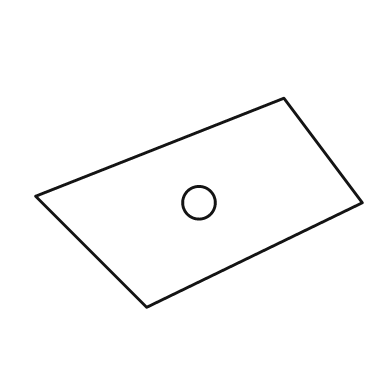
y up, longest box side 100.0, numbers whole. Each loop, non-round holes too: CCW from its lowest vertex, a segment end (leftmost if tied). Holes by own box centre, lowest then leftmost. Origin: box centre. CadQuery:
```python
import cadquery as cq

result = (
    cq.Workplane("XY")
    .moveTo(-16.0, -32.0)
    .lineTo(50.0, 0.0)
    .lineTo(26.0, 32.0)
    .lineTo(-50.0, 2.0)
    .close()
    .moveTo(0.0, 0.0)
    .circle(5.0)
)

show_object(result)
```